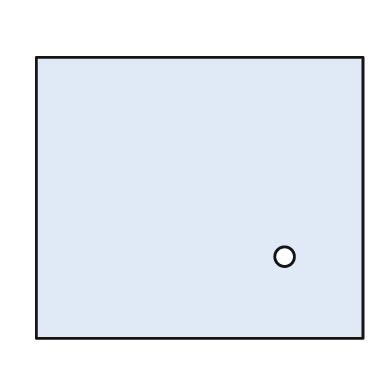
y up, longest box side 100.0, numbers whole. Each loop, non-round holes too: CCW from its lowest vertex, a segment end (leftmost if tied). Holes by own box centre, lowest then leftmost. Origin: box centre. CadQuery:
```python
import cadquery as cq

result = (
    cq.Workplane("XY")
    .moveTo(-50.0, -43.0)
    .lineTo(50.0, -43.0)
    .lineTo(50.0, 43.0)
    .lineTo(-50.0, 43.0)
    .close()
    .moveTo(26.0, -18.0)
    .circle(3.0)
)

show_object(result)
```